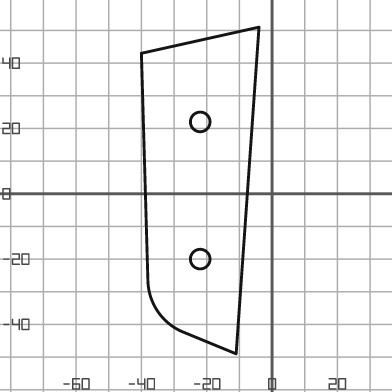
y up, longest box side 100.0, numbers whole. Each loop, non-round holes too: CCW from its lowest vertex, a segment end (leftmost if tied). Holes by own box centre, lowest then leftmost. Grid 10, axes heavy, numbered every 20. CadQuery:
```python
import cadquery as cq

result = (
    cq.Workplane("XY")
    .moveTo(-11.0, -49.0)
    .lineTo(-4.0, 51.0)
    .lineTo(-40.0, 43.0)
    .lineTo(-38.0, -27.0)
    .threePointArc((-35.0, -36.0), (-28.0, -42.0))
    .close()
    .moveTo(-22.0, -20.0)
    .circle(3.0)
    .moveTo(-22.0, 22.0)
    .circle(3.0)
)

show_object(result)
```